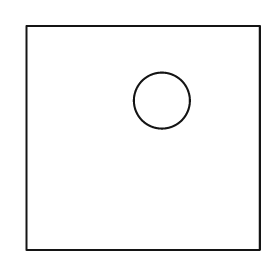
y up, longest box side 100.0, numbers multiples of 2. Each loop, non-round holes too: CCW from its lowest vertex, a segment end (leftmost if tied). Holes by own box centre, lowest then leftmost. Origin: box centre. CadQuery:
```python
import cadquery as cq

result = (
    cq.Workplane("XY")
    .moveTo(-50.0, -48.0)
    .lineTo(50.0, -48.0)
    .lineTo(50.0, 48.0)
    .lineTo(-50.0, 48.0)
    .close()
    .moveTo(8.0, 16.0)
    .circle(12.0)
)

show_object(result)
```